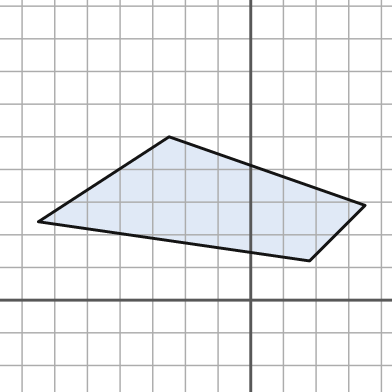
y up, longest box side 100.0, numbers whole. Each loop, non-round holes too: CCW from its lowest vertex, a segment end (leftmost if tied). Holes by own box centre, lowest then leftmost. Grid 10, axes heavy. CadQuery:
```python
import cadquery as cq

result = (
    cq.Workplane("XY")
    .moveTo(18.0, 12.0)
    .lineTo(35.0, 29.0)
    .lineTo(-25.0, 50.0)
    .lineTo(-65.0, 24.0)
    .close()
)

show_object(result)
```